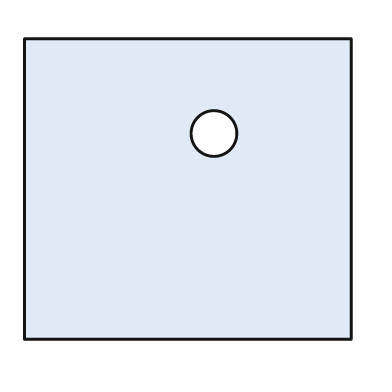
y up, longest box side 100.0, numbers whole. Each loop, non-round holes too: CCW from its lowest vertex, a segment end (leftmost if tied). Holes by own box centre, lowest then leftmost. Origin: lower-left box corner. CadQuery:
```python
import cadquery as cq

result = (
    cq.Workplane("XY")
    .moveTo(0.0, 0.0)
    .lineTo(100.0, 0.0)
    .lineTo(100.0, 92.0)
    .lineTo(0.0, 92.0)
    .close()
    .moveTo(58.0, 63.0)
    .circle(7.0)
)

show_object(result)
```